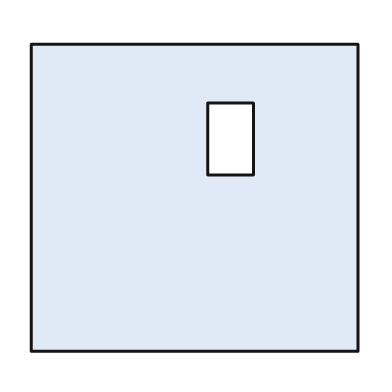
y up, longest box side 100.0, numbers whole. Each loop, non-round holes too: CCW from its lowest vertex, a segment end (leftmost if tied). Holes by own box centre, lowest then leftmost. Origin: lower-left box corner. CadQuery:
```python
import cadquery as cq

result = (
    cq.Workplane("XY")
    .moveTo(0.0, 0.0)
    .lineTo(100.0, 0.0)
    .lineTo(100.0, 94.0)
    .lineTo(0.0, 94.0)
    .close()
    .moveTo(54.0, 54.0)
    .lineTo(68.0, 54.0)
    .lineTo(68.0, 76.0)
    .lineTo(54.0, 76.0)
    .close()
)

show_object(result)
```